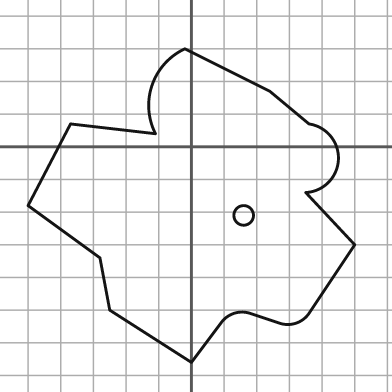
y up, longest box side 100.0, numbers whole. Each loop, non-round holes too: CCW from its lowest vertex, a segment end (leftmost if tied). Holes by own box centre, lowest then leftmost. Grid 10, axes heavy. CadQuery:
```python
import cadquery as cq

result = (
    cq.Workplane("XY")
    .moveTo(0.0, -66.0)
    .lineTo(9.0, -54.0)
    .threePointArc((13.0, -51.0), (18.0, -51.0))
    .lineTo(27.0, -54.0)
    .threePointArc((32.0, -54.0), (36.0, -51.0))
    .lineTo(50.0, -30.0)
    .lineTo(35.0, -14.0)
    .threePointArc((45.0, -4.0), (36.0, 7.0))
    .lineTo(24.0, 17.0)
    .lineTo(-2.0, 30.0)
    .threePointArc((-12.0, 19.0), (-11.0, 4.0))
    .lineTo(-37.0, 7.0)
    .lineTo(-50.0, -18.0)
    .lineTo(-28.0, -34.0)
    .lineTo(-25.0, -50.0)
    .close()
    .moveTo(16.0, -21.0)
    .circle(3.0)
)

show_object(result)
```